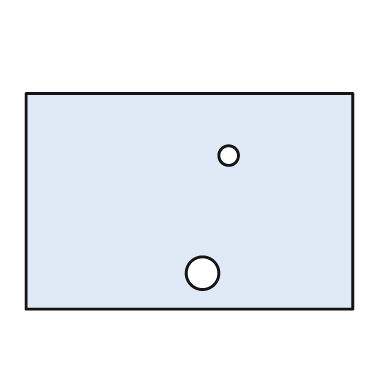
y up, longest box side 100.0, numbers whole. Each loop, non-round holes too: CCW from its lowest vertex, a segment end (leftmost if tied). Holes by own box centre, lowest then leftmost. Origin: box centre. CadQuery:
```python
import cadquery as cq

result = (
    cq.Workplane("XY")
    .moveTo(-50.0, -33.0)
    .lineTo(50.0, -33.0)
    .lineTo(50.0, 33.0)
    .lineTo(-50.0, 33.0)
    .close()
    .moveTo(4.0, -22.0)
    .circle(5.0)
    .moveTo(12.0, 14.0)
    .circle(3.0)
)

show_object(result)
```